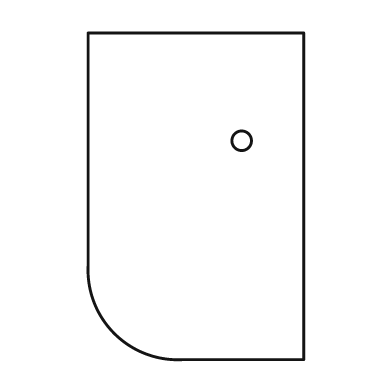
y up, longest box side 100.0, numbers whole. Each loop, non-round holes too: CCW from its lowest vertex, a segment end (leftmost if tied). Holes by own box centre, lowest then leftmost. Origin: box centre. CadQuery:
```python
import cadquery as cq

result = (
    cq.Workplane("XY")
    .moveTo(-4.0, -50.0)
    .lineTo(33.0, -50.0)
    .lineTo(33.0, 50.0)
    .lineTo(-33.0, 50.0)
    .lineTo(-33.0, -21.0)
    .threePointArc((-25.0, -42.0), (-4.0, -50.0))
    .close()
    .moveTo(14.0, 17.0)
    .circle(3.0)
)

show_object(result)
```